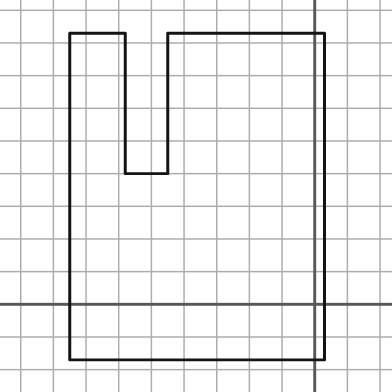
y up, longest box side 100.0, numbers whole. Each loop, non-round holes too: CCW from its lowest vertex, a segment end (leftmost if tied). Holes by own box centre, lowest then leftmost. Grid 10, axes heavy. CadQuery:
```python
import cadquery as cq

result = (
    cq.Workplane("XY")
    .moveTo(-75.0, -17.0)
    .lineTo(3.0, -17.0)
    .lineTo(3.0, 83.0)
    .lineTo(-45.0, 83.0)
    .lineTo(-45.0, 40.0)
    .lineTo(-58.0, 40.0)
    .lineTo(-58.0, 83.0)
    .lineTo(-75.0, 83.0)
    .close()
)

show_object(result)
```